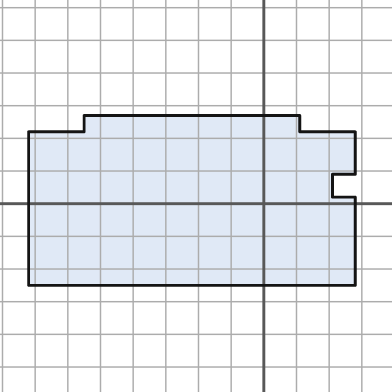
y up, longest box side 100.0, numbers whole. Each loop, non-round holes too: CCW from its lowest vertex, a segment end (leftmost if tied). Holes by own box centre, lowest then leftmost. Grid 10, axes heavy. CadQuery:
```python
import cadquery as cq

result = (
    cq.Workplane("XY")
    .moveTo(-72.0, -25.0)
    .lineTo(28.0, -25.0)
    .lineTo(28.0, 2.0)
    .lineTo(21.0, 2.0)
    .lineTo(21.0, 9.0)
    .lineTo(28.0, 9.0)
    .lineTo(28.0, 22.0)
    .lineTo(11.0, 22.0)
    .lineTo(11.0, 27.0)
    .lineTo(-55.0, 27.0)
    .lineTo(-55.0, 22.0)
    .lineTo(-72.0, 22.0)
    .close()
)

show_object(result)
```